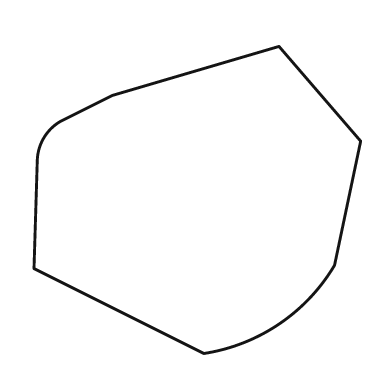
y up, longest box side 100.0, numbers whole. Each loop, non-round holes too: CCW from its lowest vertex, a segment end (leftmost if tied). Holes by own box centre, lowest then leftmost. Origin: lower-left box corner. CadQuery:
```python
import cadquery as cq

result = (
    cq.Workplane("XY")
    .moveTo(52.0, 0.0)
    .threePointArc((75.0, 9.0), (92.0, 27.0))
    .lineTo(100.0, 65.0)
    .lineTo(75.0, 94.0)
    .lineTo(24.0, 79.0)
    .lineTo(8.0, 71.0)
    .threePointArc((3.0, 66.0), (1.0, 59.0))
    .lineTo(0.0, 26.0)
    .close()
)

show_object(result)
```